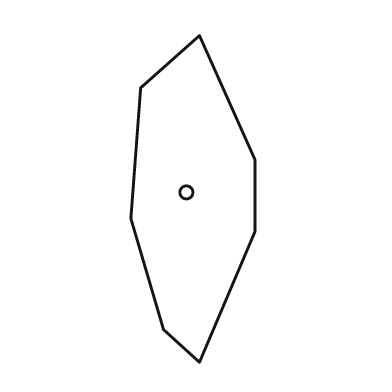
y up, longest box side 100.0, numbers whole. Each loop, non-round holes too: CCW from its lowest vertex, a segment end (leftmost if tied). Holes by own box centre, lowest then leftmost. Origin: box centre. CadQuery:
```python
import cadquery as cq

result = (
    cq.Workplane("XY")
    .moveTo(2.0, -50.0)
    .lineTo(19.0, -10.0)
    .lineTo(19.0, 12.0)
    .lineTo(2.0, 50.0)
    .lineTo(-16.0, 34.0)
    .lineTo(-19.0, -6.0)
    .lineTo(-9.0, -40.0)
    .close()
    .moveTo(-2.0, 2.0)
    .circle(2.0)
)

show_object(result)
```